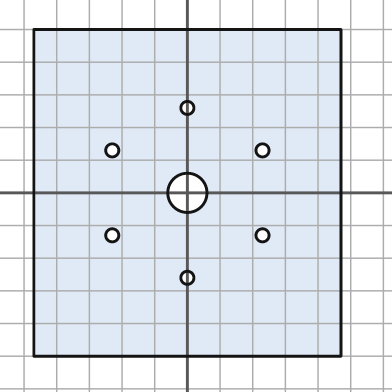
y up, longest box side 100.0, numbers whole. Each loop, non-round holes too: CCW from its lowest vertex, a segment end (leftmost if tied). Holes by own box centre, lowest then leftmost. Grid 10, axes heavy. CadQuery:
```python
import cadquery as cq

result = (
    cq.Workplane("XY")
    .moveTo(-47.0, -50.0)
    .lineTo(47.0, -50.0)
    .lineTo(47.0, 50.0)
    .lineTo(-47.0, 50.0)
    .close()
    .moveTo(0.0, -26.0)
    .circle(2.0)
    .moveTo(-23.0, -13.0)
    .circle(2.0)
    .moveTo(23.0, -13.0)
    .circle(2.0)
    .moveTo(0.0, 0.0)
    .circle(6.0)
    .moveTo(-23.0, 13.0)
    .circle(2.0)
    .moveTo(23.0, 13.0)
    .circle(2.0)
    .moveTo(0.0, 26.0)
    .circle(2.0)
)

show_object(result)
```